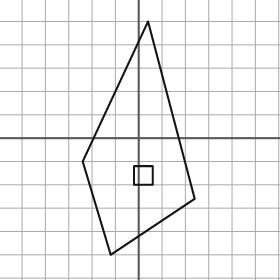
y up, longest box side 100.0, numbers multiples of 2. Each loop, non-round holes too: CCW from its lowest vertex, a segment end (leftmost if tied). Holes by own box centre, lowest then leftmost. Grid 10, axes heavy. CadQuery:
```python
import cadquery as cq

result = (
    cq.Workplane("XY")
    .moveTo(-12.0, -50.0)
    .lineTo(24.0, -26.0)
    .lineTo(4.0, 50.0)
    .lineTo(-24.0, -10.0)
    .close()
    .moveTo(-2.0, -20.0)
    .lineTo(6.0, -20.0)
    .lineTo(6.0, -12.0)
    .lineTo(-2.0, -12.0)
    .close()
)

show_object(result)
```